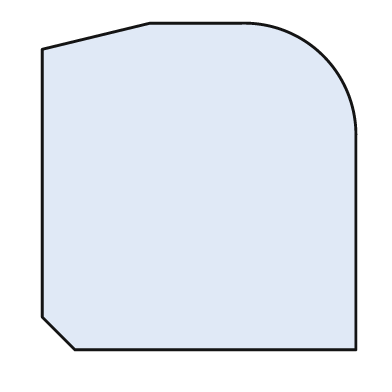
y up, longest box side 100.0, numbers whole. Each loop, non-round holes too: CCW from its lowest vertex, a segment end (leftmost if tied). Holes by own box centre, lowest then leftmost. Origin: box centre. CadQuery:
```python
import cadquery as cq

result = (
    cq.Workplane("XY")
    .moveTo(-38.0, -50.0)
    .lineTo(48.0, -50.0)
    .lineTo(48.0, 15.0)
    .threePointArc((38.0, 40.0), (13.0, 50.0))
    .lineTo(-15.0, 50.0)
    .lineTo(-48.0, 42.0)
    .lineTo(-48.0, -40.0)
    .close()
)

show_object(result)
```